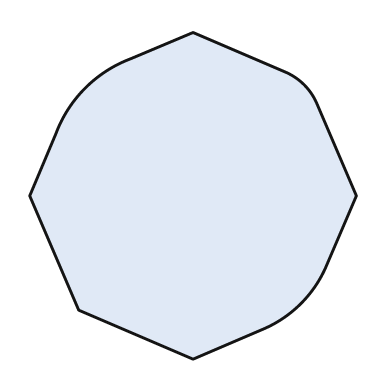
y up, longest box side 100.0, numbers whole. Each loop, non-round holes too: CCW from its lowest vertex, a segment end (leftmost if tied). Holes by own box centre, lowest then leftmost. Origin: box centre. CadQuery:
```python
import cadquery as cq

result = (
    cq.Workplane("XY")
    .moveTo(0.0, -50.0)
    .lineTo(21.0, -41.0)
    .threePointArc((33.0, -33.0), (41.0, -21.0))
    .lineTo(50.0, 0.0)
    .lineTo(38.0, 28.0)
    .threePointArc((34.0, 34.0), (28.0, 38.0))
    .lineTo(0.0, 50.0)
    .lineTo(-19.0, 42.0)
    .threePointArc((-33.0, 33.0), (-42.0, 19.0))
    .lineTo(-50.0, 0.0)
    .lineTo(-35.0, -35.0)
    .close()
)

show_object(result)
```